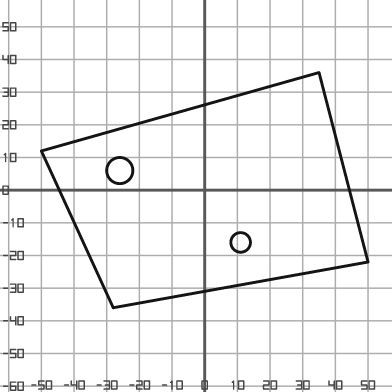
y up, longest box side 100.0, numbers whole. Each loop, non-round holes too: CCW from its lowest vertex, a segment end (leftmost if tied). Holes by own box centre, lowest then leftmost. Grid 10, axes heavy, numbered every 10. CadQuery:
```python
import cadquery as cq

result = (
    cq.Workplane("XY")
    .moveTo(-28.0, -36.0)
    .lineTo(50.0, -22.0)
    .lineTo(35.0, 36.0)
    .lineTo(-50.0, 12.0)
    .close()
    .moveTo(11.0, -16.0)
    .circle(3.0)
    .moveTo(-26.0, 6.0)
    .circle(4.0)
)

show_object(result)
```